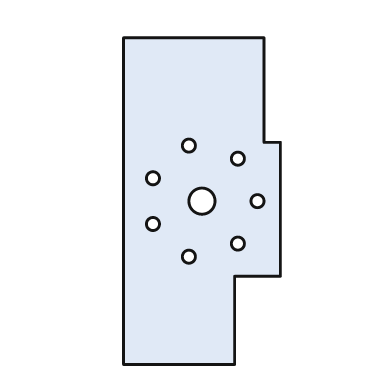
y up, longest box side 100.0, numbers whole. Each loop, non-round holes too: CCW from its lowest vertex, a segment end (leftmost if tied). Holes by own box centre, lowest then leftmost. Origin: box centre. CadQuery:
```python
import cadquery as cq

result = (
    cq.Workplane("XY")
    .moveTo(-24.0, -50.0)
    .lineTo(10.0, -50.0)
    .lineTo(10.0, -23.0)
    .lineTo(24.0, -23.0)
    .lineTo(24.0, 18.0)
    .lineTo(19.0, 18.0)
    .lineTo(19.0, 50.0)
    .lineTo(-24.0, 50.0)
    .close()
    .moveTo(-4.0, -17.0)
    .circle(2.0)
    .moveTo(11.0, -13.0)
    .circle(2.0)
    .moveTo(-15.0, -7.0)
    .circle(2.0)
    .moveTo(0.0, 0.0)
    .circle(4.0)
    .moveTo(17.0, 0.0)
    .circle(2.0)
    .moveTo(-15.0, 7.0)
    .circle(2.0)
    .moveTo(11.0, 13.0)
    .circle(2.0)
    .moveTo(-4.0, 17.0)
    .circle(2.0)
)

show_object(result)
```